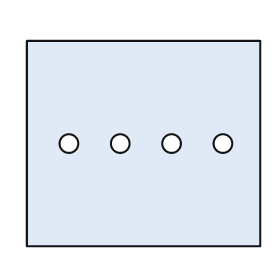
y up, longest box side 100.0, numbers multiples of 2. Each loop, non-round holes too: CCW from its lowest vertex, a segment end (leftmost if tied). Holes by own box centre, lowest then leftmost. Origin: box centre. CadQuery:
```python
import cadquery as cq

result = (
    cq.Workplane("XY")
    .moveTo(-50.0, -44.0)
    .lineTo(50.0, -44.0)
    .lineTo(50.0, 44.0)
    .lineTo(-50.0, 44.0)
    .close()
    .moveTo(-32.0, 0.0)
    .circle(4.0)
    .moveTo(-10.0, 0.0)
    .circle(4.0)
    .moveTo(12.0, 0.0)
    .circle(4.0)
    .moveTo(34.0, 0.0)
    .circle(4.0)
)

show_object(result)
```